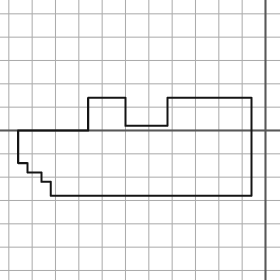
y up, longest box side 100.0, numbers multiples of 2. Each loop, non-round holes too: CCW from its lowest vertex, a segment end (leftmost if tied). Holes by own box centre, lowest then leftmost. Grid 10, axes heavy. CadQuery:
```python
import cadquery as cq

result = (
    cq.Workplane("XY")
    .moveTo(-92.0, -28.0)
    .lineTo(-6.0, -28.0)
    .lineTo(-6.0, 14.0)
    .lineTo(-42.0, 14.0)
    .lineTo(-42.0, 2.0)
    .lineTo(-60.0, 2.0)
    .lineTo(-60.0, 14.0)
    .lineTo(-76.0, 14.0)
    .lineTo(-76.0, 0.0)
    .lineTo(-106.0, 0.0)
    .lineTo(-106.0, -14.0)
    .lineTo(-102.0, -14.0)
    .lineTo(-102.0, -18.0)
    .lineTo(-96.0, -18.0)
    .lineTo(-96.0, -22.0)
    .lineTo(-92.0, -22.0)
    .close()
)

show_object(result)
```